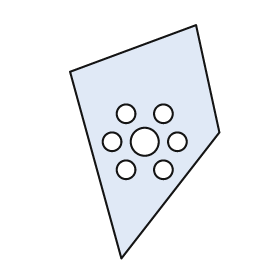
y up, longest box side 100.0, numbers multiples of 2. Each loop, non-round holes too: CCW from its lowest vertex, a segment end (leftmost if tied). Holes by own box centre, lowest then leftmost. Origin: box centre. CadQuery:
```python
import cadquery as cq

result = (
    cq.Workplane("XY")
    .moveTo(-10.0, -50.0)
    .lineTo(32.0, 4.0)
    .lineTo(22.0, 50.0)
    .lineTo(-32.0, 30.0)
    .close()
    .moveTo(-8.0, -12.0)
    .circle(4.0)
    .moveTo(8.0, -12.0)
    .circle(4.0)
    .moveTo(-14.0, 0.0)
    .circle(4.0)
    .moveTo(0.0, 0.0)
    .circle(6.0)
    .moveTo(14.0, 0.0)
    .circle(4.0)
    .moveTo(-8.0, 12.0)
    .circle(4.0)
    .moveTo(8.0, 12.0)
    .circle(4.0)
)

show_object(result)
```